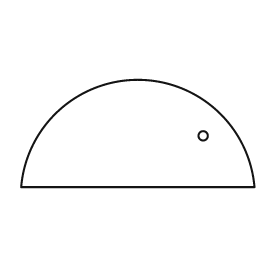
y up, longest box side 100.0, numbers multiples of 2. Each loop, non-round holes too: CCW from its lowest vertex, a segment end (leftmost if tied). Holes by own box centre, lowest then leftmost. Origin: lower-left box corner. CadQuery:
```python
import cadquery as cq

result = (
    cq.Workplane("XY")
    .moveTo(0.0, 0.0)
    .lineTo(100.0, 0.0)
    .threePointArc((50.0, 46.0), (0.0, 0.0))
    .close()
    .moveTo(78.0, 22.0)
    .circle(2.0)
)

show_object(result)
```